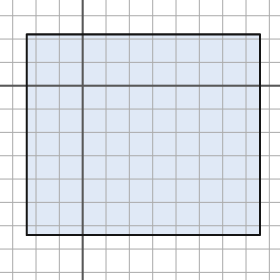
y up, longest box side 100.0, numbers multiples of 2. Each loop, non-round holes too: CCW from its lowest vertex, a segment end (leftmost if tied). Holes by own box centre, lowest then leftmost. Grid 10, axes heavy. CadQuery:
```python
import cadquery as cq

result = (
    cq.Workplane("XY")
    .moveTo(-24.0, -64.0)
    .lineTo(76.0, -64.0)
    .lineTo(76.0, 22.0)
    .lineTo(-24.0, 22.0)
    .close()
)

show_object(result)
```